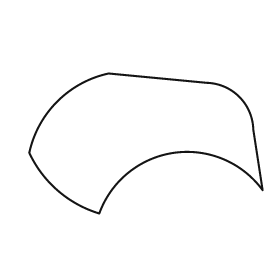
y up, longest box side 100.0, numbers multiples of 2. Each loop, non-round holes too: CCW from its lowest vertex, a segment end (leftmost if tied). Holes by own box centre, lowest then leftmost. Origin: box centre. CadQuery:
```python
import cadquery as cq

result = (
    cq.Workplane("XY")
    .moveTo(-20.0, -30.0)
    .threePointArc((12.0, -4.0), (50.0, -20.0))
    .lineTo(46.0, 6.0)
    .threePointArc((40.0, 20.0), (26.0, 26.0))
    .lineTo(-16.0, 30.0)
    .threePointArc((-38.0, 18.0), (-50.0, -4.0))
    .threePointArc((-38.0, -20.0), (-20.0, -30.0))
    .close()
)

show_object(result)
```